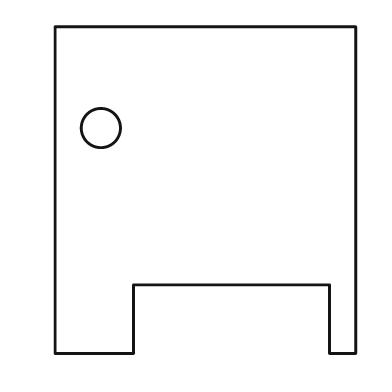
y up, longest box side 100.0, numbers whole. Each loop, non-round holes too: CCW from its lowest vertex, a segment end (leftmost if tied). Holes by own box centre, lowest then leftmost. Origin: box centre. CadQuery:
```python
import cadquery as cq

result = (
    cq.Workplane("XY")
    .moveTo(-46.0, -50.0)
    .lineTo(-22.0, -50.0)
    .lineTo(-22.0, -29.0)
    .lineTo(38.0, -29.0)
    .lineTo(38.0, -50.0)
    .lineTo(46.0, -50.0)
    .lineTo(46.0, 50.0)
    .lineTo(-46.0, 50.0)
    .close()
    .moveTo(-32.0, 19.0)
    .circle(6.0)
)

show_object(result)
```